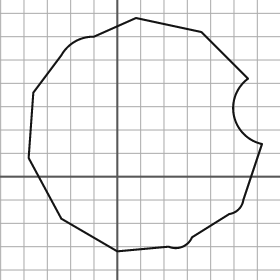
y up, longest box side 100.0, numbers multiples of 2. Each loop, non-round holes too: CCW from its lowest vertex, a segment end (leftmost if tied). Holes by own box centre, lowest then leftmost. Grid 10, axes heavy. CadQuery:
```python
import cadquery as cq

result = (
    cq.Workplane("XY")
    .moveTo(0.0, -32.0)
    .lineTo(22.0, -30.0)
    .threePointArc((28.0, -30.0), (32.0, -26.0))
    .lineTo(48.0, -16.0)
    .threePointArc((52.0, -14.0), (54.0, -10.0))
    .lineTo(62.0, 14.0)
    .threePointArc((50.0, 26.0), (56.0, 42.0))
    .lineTo(36.0, 62.0)
    .lineTo(8.0, 68.0)
    .lineTo(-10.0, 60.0)
    .threePointArc((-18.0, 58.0), (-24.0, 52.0))
    .lineTo(-36.0, 36.0)
    .lineTo(-38.0, 8.0)
    .lineTo(-24.0, -18.0)
    .close()
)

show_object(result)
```